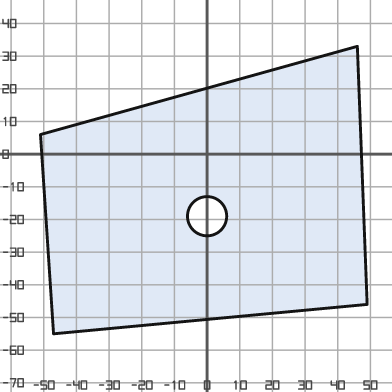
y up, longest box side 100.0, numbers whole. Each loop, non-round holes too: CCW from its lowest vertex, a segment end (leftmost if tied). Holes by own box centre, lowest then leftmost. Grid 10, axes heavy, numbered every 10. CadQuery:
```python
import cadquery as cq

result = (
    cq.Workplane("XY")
    .moveTo(-47.0, -55.0)
    .lineTo(49.0, -46.0)
    .lineTo(46.0, 33.0)
    .lineTo(-51.0, 6.0)
    .close()
    .moveTo(0.0, -19.0)
    .circle(6.0)
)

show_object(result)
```